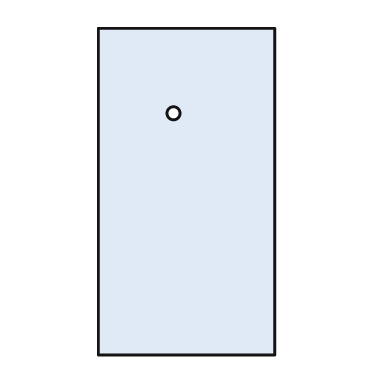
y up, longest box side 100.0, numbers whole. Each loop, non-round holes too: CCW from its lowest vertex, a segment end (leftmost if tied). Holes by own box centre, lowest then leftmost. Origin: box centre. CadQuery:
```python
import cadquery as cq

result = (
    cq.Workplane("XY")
    .moveTo(-27.0, -50.0)
    .lineTo(27.0, -50.0)
    .lineTo(27.0, 50.0)
    .lineTo(-27.0, 50.0)
    .close()
    .moveTo(-4.0, 24.0)
    .circle(2.0)
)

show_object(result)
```